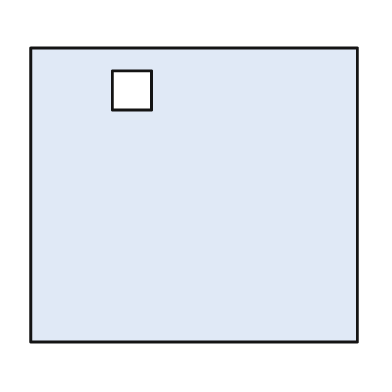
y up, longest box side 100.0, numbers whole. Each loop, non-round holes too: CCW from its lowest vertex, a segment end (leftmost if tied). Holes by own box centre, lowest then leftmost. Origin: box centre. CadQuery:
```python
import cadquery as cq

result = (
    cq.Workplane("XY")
    .moveTo(-50.0, -45.0)
    .lineTo(50.0, -45.0)
    .lineTo(50.0, 45.0)
    .lineTo(-50.0, 45.0)
    .close()
    .moveTo(-25.0, 26.0)
    .lineTo(-13.0, 26.0)
    .lineTo(-13.0, 38.0)
    .lineTo(-25.0, 38.0)
    .close()
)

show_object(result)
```